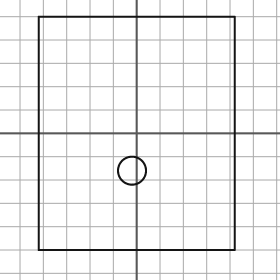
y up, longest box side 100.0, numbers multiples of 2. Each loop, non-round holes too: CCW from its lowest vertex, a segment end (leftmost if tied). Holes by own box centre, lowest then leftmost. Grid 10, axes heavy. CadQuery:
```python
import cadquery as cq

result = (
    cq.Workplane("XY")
    .moveTo(-42.0, -50.0)
    .lineTo(42.0, -50.0)
    .lineTo(42.0, 50.0)
    .lineTo(-42.0, 50.0)
    .close()
    .moveTo(-2.0, -16.0)
    .circle(6.0)
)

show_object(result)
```